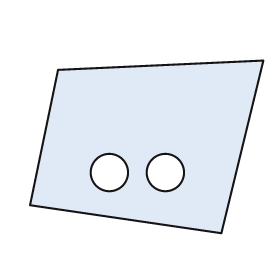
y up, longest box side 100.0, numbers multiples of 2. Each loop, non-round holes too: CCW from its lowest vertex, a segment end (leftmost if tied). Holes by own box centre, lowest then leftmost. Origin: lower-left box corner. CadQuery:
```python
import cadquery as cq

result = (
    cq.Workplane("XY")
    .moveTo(82.0, 0.0)
    .lineTo(100.0, 74.0)
    .lineTo(12.0, 70.0)
    .lineTo(0.0, 12.0)
    .close()
    .moveTo(34.0, 26.0)
    .circle(8.0)
    .moveTo(58.0, 26.0)
    .circle(8.0)
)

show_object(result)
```